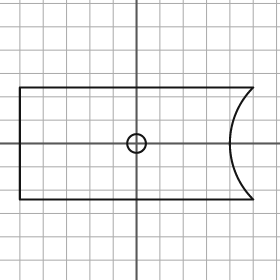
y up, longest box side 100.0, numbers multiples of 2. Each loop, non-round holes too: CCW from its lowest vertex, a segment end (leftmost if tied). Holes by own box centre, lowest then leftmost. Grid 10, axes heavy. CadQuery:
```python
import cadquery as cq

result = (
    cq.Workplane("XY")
    .moveTo(-50.0, -24.0)
    .lineTo(50.0, -24.0)
    .threePointArc((40.0, 0.0), (50.0, 24.0))
    .lineTo(-50.0, 24.0)
    .close()
    .moveTo(0.0, 0.0)
    .circle(4.0)
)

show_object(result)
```